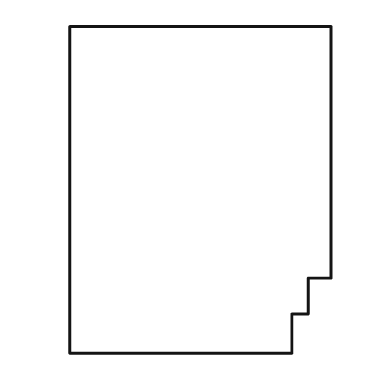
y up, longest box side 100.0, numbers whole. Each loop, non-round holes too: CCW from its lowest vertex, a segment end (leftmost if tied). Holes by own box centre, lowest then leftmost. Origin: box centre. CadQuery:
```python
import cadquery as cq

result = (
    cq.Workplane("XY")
    .moveTo(-40.0, -50.0)
    .lineTo(28.0, -50.0)
    .lineTo(28.0, -38.0)
    .lineTo(33.0, -38.0)
    .lineTo(33.0, -27.0)
    .lineTo(40.0, -27.0)
    .lineTo(40.0, 50.0)
    .lineTo(-40.0, 50.0)
    .close()
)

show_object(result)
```